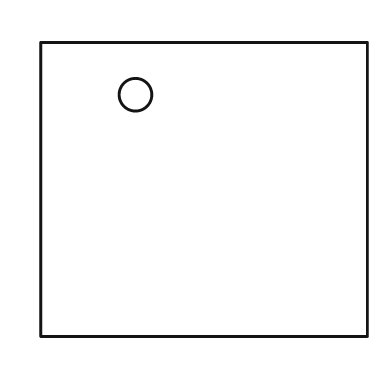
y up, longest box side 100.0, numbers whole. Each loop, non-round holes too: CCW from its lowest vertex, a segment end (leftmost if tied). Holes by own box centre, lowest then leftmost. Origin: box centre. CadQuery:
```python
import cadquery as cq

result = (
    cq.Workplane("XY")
    .moveTo(-50.0, -45.0)
    .lineTo(50.0, -45.0)
    .lineTo(50.0, 45.0)
    .lineTo(-50.0, 45.0)
    .close()
    .moveTo(-21.0, 29.0)
    .circle(5.0)
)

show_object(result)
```